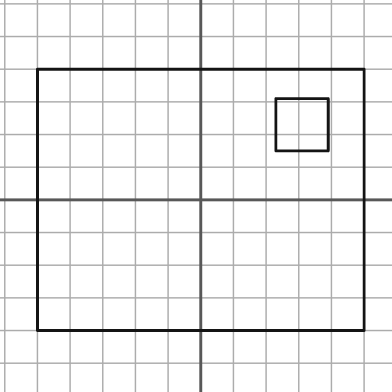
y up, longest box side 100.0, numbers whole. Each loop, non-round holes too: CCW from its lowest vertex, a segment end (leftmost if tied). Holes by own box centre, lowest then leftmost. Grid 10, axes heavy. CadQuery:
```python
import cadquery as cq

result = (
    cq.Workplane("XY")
    .moveTo(-50.0, -40.0)
    .lineTo(50.0, -40.0)
    .lineTo(50.0, 40.0)
    .lineTo(-50.0, 40.0)
    .close()
    .moveTo(23.0, 15.0)
    .lineTo(39.0, 15.0)
    .lineTo(39.0, 31.0)
    .lineTo(23.0, 31.0)
    .close()
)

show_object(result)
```